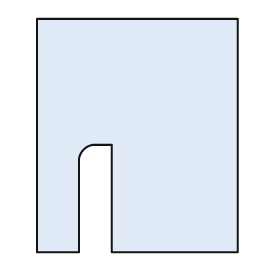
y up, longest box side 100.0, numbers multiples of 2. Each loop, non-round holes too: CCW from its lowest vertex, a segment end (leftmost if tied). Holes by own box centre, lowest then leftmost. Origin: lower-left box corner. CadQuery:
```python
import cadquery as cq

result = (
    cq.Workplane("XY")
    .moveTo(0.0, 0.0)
    .lineTo(18.0, 0.0)
    .lineTo(18.0, 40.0)
    .threePointArc((20.0, 44.0), (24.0, 46.0))
    .lineTo(32.0, 46.0)
    .lineTo(32.0, 0.0)
    .lineTo(86.0, 0.0)
    .lineTo(86.0, 100.0)
    .lineTo(0.0, 100.0)
    .close()
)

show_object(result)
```